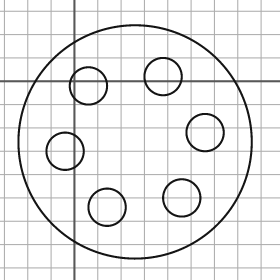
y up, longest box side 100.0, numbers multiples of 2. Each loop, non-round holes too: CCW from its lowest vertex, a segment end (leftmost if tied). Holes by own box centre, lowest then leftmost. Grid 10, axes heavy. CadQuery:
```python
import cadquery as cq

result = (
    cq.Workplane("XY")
    .moveTo(26.0, -26.0)
    .circle(50.0)
    .moveTo(14.0, -54.0)
    .circle(8.0)
    .moveTo(46.0, -50.0)
    .circle(8.0)
    .moveTo(-4.0, -30.0)
    .circle(8.0)
    .moveTo(56.0, -22.0)
    .circle(8.0)
    .moveTo(6.0, -2.0)
    .circle(8.0)
    .moveTo(38.0, 2.0)
    .circle(8.0)
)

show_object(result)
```